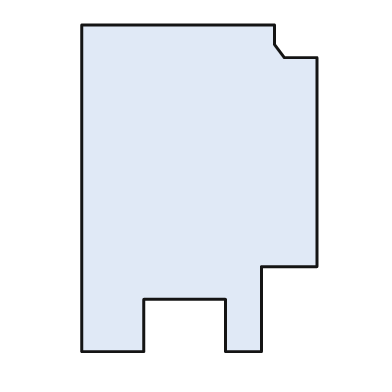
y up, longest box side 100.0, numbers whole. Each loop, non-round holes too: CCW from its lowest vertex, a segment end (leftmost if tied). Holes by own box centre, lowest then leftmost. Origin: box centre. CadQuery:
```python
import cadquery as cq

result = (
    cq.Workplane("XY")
    .moveTo(-36.0, -50.0)
    .lineTo(-17.0, -50.0)
    .lineTo(-17.0, -34.0)
    .lineTo(8.0, -34.0)
    .lineTo(8.0, -50.0)
    .lineTo(19.0, -50.0)
    .lineTo(19.0, -24.0)
    .lineTo(36.0, -24.0)
    .lineTo(36.0, 40.0)
    .lineTo(26.0, 40.0)
    .lineTo(23.0, 44.0)
    .lineTo(23.0, 50.0)
    .lineTo(-36.0, 50.0)
    .close()
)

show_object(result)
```